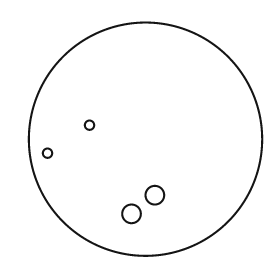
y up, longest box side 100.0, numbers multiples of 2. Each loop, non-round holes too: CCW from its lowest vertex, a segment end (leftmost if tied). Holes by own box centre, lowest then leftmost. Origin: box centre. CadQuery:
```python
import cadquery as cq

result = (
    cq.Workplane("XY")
    .moveTo(0.0, 0.0)
    .circle(50.0)
    .moveTo(-6.0, -32.0)
    .circle(4.0)
    .moveTo(4.0, -24.0)
    .circle(4.0)
    .moveTo(-42.0, -6.0)
    .circle(2.0)
    .moveTo(-24.0, 6.0)
    .circle(2.0)
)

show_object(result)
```